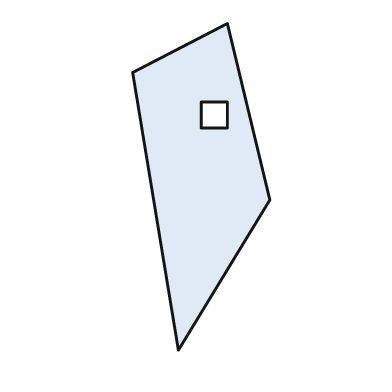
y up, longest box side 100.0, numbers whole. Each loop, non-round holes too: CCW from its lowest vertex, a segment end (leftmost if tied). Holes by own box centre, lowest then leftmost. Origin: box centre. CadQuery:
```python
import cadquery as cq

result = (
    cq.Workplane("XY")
    .moveTo(-7.0, -50.0)
    .lineTo(21.0, -4.0)
    .lineTo(8.0, 50.0)
    .lineTo(-21.0, 35.0)
    .close()
    .moveTo(0.0, 18.0)
    .lineTo(8.0, 18.0)
    .lineTo(8.0, 26.0)
    .lineTo(0.0, 26.0)
    .close()
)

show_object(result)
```